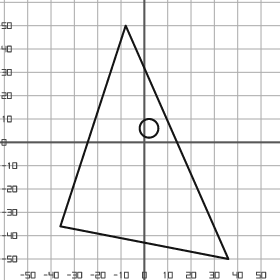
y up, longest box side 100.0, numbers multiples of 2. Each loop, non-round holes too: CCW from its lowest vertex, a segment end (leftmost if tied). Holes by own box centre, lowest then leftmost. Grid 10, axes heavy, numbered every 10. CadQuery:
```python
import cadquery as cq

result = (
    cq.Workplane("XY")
    .moveTo(36.0, -50.0)
    .lineTo(-8.0, 50.0)
    .lineTo(-36.0, -36.0)
    .close()
    .moveTo(2.0, 6.0)
    .circle(4.0)
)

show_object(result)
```